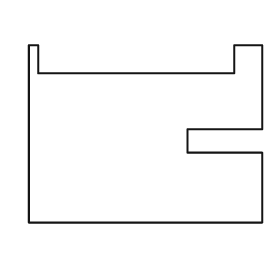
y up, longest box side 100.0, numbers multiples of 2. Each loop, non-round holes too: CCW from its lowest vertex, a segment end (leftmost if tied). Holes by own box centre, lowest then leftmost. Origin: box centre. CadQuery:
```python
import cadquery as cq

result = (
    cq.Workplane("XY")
    .moveTo(-50.0, -38.0)
    .lineTo(50.0, -38.0)
    .lineTo(50.0, -8.0)
    .lineTo(18.0, -8.0)
    .lineTo(18.0, 2.0)
    .lineTo(50.0, 2.0)
    .lineTo(50.0, 38.0)
    .lineTo(38.0, 38.0)
    .lineTo(38.0, 26.0)
    .lineTo(-46.0, 26.0)
    .lineTo(-46.0, 38.0)
    .lineTo(-50.0, 38.0)
    .close()
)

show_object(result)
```